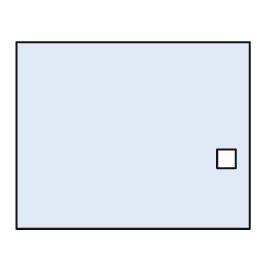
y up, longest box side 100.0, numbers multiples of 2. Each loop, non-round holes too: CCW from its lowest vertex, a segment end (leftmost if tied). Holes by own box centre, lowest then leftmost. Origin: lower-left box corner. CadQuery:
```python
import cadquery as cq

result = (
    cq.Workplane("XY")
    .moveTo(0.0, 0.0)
    .lineTo(100.0, 0.0)
    .lineTo(100.0, 80.0)
    .lineTo(0.0, 80.0)
    .close()
    .moveTo(86.0, 26.0)
    .lineTo(94.0, 26.0)
    .lineTo(94.0, 34.0)
    .lineTo(86.0, 34.0)
    .close()
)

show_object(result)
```